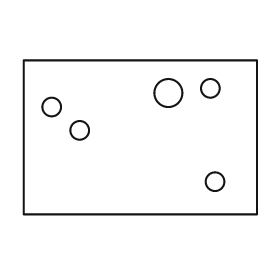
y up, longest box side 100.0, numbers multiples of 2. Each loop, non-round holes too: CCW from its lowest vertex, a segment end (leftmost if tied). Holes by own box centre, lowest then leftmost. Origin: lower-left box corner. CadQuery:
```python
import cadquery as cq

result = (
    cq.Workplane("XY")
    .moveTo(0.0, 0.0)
    .lineTo(100.0, 0.0)
    .lineTo(100.0, 66.0)
    .lineTo(0.0, 66.0)
    .close()
    .moveTo(82.0, 14.0)
    .circle(4.0)
    .moveTo(24.0, 36.0)
    .circle(4.0)
    .moveTo(12.0, 46.0)
    .circle(4.0)
    .moveTo(62.0, 52.0)
    .circle(6.0)
    .moveTo(80.0, 54.0)
    .circle(4.0)
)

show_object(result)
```